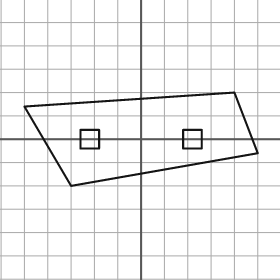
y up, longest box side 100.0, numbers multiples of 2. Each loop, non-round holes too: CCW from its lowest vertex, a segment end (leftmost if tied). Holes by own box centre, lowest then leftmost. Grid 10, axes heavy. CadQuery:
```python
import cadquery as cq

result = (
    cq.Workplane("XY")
    .moveTo(-30.0, -20.0)
    .lineTo(50.0, -6.0)
    .lineTo(40.0, 20.0)
    .lineTo(-50.0, 14.0)
    .close()
    .moveTo(-26.0, -4.0)
    .lineTo(-18.0, -4.0)
    .lineTo(-18.0, 4.0)
    .lineTo(-26.0, 4.0)
    .close()
    .moveTo(18.0, -4.0)
    .lineTo(26.0, -4.0)
    .lineTo(26.0, 4.0)
    .lineTo(18.0, 4.0)
    .close()
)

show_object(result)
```